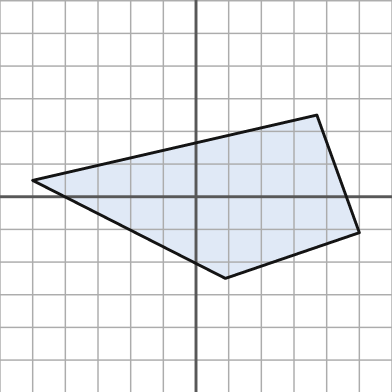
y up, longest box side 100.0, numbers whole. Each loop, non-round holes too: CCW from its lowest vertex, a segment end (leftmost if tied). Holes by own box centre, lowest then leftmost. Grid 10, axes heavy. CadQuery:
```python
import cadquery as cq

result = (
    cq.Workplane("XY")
    .moveTo(9.0, -25.0)
    .lineTo(50.0, -11.0)
    .lineTo(37.0, 25.0)
    .lineTo(-50.0, 5.0)
    .close()
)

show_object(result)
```